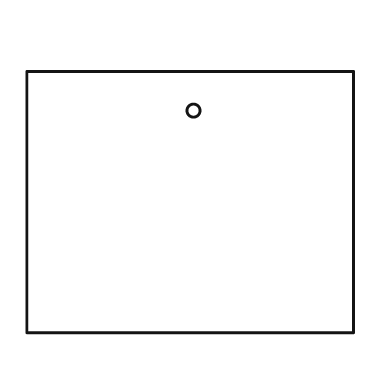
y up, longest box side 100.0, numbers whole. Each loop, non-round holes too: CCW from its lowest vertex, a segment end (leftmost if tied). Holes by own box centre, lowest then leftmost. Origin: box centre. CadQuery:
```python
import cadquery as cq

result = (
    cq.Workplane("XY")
    .moveTo(-50.0, -40.0)
    .lineTo(50.0, -40.0)
    .lineTo(50.0, 40.0)
    .lineTo(-50.0, 40.0)
    .close()
    .moveTo(1.0, 28.0)
    .circle(2.0)
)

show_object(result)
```